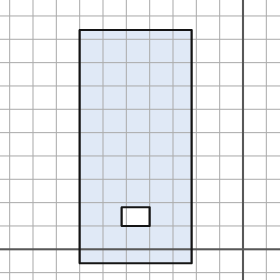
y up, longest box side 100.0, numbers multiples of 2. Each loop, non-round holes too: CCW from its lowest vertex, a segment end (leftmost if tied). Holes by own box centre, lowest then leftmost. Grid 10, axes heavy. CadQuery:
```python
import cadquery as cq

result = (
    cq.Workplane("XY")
    .moveTo(-70.0, -6.0)
    .lineTo(-22.0, -6.0)
    .lineTo(-22.0, 94.0)
    .lineTo(-70.0, 94.0)
    .close()
    .moveTo(-52.0, 10.0)
    .lineTo(-40.0, 10.0)
    .lineTo(-40.0, 18.0)
    .lineTo(-52.0, 18.0)
    .close()
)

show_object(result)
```